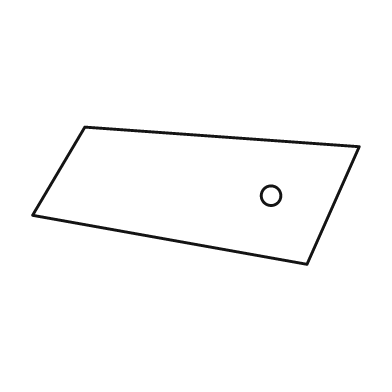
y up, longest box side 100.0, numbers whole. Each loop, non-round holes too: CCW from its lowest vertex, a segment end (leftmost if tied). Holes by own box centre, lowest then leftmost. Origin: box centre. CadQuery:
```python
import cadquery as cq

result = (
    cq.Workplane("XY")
    .moveTo(34.0, -21.0)
    .lineTo(50.0, 15.0)
    .lineTo(-34.0, 21.0)
    .lineTo(-50.0, -6.0)
    .close()
    .moveTo(23.0, 0.0)
    .circle(3.0)
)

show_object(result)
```